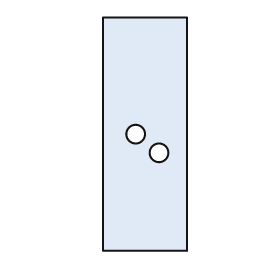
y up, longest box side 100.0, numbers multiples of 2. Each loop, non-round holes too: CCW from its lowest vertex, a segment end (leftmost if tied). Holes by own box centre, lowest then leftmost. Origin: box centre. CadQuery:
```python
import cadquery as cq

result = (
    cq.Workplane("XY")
    .moveTo(-18.0, -50.0)
    .lineTo(18.0, -50.0)
    .lineTo(18.0, 50.0)
    .lineTo(-18.0, 50.0)
    .close()
    .moveTo(6.0, -8.0)
    .circle(4.0)
    .moveTo(-4.0, 0.0)
    .circle(4.0)
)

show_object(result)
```